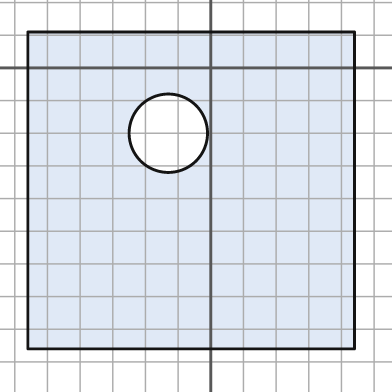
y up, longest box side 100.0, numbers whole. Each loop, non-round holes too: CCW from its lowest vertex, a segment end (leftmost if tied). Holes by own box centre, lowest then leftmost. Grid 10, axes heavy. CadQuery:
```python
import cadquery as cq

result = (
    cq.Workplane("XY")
    .moveTo(-56.0, -86.0)
    .lineTo(44.0, -86.0)
    .lineTo(44.0, 11.0)
    .lineTo(-56.0, 11.0)
    .close()
    .moveTo(-13.0, -20.0)
    .circle(12.0)
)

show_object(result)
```